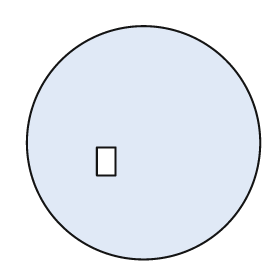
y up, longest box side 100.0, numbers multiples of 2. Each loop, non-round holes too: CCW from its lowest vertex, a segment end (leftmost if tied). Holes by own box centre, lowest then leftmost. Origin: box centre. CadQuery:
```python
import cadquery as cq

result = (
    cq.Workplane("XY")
    .moveTo(0.0, 0.0)
    .circle(50.0)
    .moveTo(-20.0, -14.0)
    .lineTo(-12.0, -14.0)
    .lineTo(-12.0, -2.0)
    .lineTo(-20.0, -2.0)
    .close()
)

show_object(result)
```